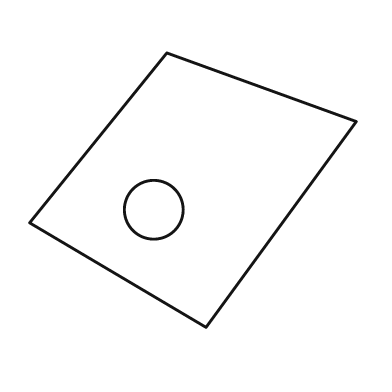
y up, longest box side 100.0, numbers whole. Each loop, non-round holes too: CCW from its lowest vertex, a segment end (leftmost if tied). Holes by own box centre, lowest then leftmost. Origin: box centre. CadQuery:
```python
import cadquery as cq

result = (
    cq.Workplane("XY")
    .moveTo(4.0, -42.0)
    .lineTo(50.0, 21.0)
    .lineTo(-8.0, 42.0)
    .lineTo(-50.0, -10.0)
    .close()
    .moveTo(-12.0, -6.0)
    .circle(9.0)
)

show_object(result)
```